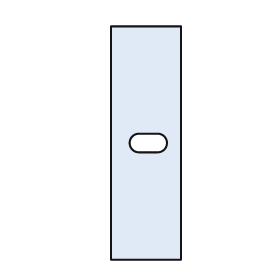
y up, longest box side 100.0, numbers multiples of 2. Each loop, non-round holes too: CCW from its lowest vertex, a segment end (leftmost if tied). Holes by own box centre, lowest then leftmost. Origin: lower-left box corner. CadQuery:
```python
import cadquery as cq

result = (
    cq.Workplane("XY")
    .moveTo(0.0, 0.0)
    .lineTo(30.0, 0.0)
    .lineTo(30.0, 100.0)
    .lineTo(0.0, 100.0)
    .close()
    .moveTo(12.0, 46.0)
    .lineTo(20.0, 46.0)
    .threePointArc((24.0, 50.0), (20.0, 54.0))
    .lineTo(12.0, 54.0)
    .threePointArc((8.0, 50.0), (12.0, 46.0))
    .close()
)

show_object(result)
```